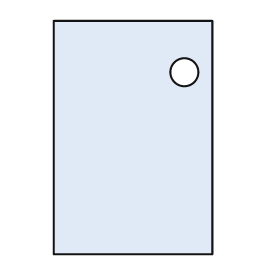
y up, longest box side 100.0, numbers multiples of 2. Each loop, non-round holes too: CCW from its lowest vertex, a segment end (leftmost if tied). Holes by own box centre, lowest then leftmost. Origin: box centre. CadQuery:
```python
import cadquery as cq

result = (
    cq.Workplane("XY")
    .moveTo(-34.0, -50.0)
    .lineTo(34.0, -50.0)
    .lineTo(34.0, 50.0)
    .lineTo(-34.0, 50.0)
    .close()
    .moveTo(22.0, 28.0)
    .circle(6.0)
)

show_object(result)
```